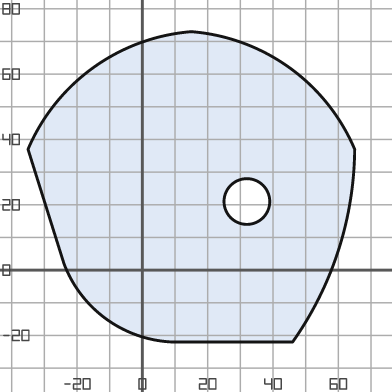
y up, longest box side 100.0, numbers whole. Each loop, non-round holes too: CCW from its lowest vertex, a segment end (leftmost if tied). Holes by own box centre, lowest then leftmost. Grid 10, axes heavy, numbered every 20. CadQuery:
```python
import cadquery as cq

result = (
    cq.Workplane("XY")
    .moveTo(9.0, -22.0)
    .lineTo(46.0, -22.0)
    .threePointArc((60.0, 6.0), (65.0, 37.0))
    .threePointArc((45.0, 62.0), (15.0, 73.0))
    .threePointArc((-15.0, 62.0), (-35.0, 37.0))
    .lineTo(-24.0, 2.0)
    .threePointArc((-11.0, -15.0), (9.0, -22.0))
    .close()
    .moveTo(32.0, 21.0)
    .circle(7.0)
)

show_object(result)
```